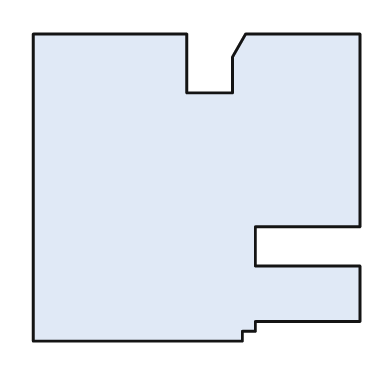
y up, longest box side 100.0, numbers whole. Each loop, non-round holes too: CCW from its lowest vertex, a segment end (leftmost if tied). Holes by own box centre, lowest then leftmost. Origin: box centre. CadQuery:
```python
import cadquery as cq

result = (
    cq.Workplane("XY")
    .moveTo(-50.0, -47.0)
    .lineTo(14.0, -47.0)
    .lineTo(14.0, -44.0)
    .lineTo(18.0, -44.0)
    .lineTo(18.0, -41.0)
    .lineTo(50.0, -41.0)
    .lineTo(50.0, -24.0)
    .lineTo(18.0, -24.0)
    .lineTo(18.0, -12.0)
    .lineTo(50.0, -12.0)
    .lineTo(50.0, 47.0)
    .lineTo(15.0, 47.0)
    .lineTo(11.0, 40.0)
    .lineTo(11.0, 29.0)
    .lineTo(-3.0, 29.0)
    .lineTo(-3.0, 47.0)
    .lineTo(-50.0, 47.0)
    .close()
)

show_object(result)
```